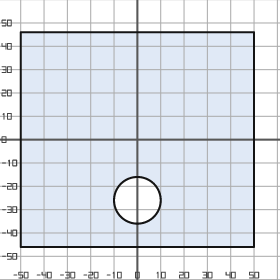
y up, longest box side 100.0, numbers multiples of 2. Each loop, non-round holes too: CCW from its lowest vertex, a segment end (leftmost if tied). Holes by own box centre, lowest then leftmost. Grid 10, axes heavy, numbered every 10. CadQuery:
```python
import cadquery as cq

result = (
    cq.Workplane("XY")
    .moveTo(-50.0, -46.0)
    .lineTo(50.0, -46.0)
    .lineTo(50.0, 46.0)
    .lineTo(-50.0, 46.0)
    .close()
    .moveTo(0.0, -26.0)
    .circle(10.0)
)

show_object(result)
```